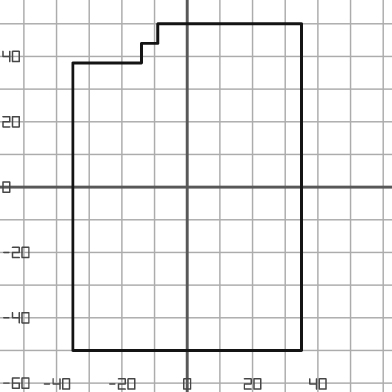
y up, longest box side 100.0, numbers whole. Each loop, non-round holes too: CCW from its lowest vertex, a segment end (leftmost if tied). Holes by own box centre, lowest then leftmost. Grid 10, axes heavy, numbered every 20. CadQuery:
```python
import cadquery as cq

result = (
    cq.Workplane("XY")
    .moveTo(-35.0, -50.0)
    .lineTo(35.0, -50.0)
    .lineTo(35.0, 50.0)
    .lineTo(-9.0, 50.0)
    .lineTo(-9.0, 44.0)
    .lineTo(-14.0, 44.0)
    .lineTo(-14.0, 38.0)
    .lineTo(-35.0, 38.0)
    .close()
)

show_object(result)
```